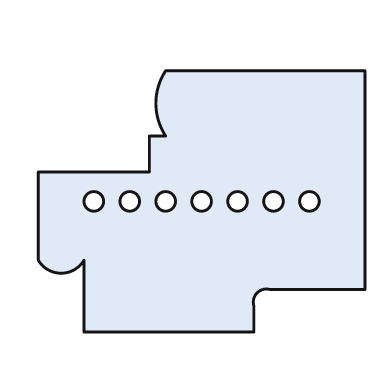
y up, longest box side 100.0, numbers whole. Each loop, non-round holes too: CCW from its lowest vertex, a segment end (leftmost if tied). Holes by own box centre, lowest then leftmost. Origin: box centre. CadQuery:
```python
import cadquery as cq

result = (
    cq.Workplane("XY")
    .moveTo(-36.0, -40.0)
    .lineTo(16.0, -40.0)
    .lineTo(16.0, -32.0)
    .threePointArc((17.0, -28.0), (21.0, -27.0))
    .lineTo(50.0, -27.0)
    .lineTo(50.0, 40.0)
    .lineTo(-11.0, 40.0)
    .threePointArc((-14.0, 30.0), (-11.0, 20.0))
    .lineTo(-16.0, 20.0)
    .lineTo(-16.0, 9.0)
    .lineTo(-50.0, 9.0)
    .lineTo(-50.0, -18.0)
    .threePointArc((-43.0, -22.0), (-36.0, -18.0))
    .close()
    .moveTo(-33.0, 0.0)
    .circle(3.0)
    .moveTo(-22.0, 0.0)
    .circle(3.0)
    .moveTo(-11.0, 0.0)
    .circle(3.0)
    .moveTo(0.0, 0.0)
    .circle(3.0)
    .moveTo(11.0, 0.0)
    .circle(3.0)
    .moveTo(22.0, 0.0)
    .circle(3.0)
    .moveTo(33.0, 0.0)
    .circle(3.0)
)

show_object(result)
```